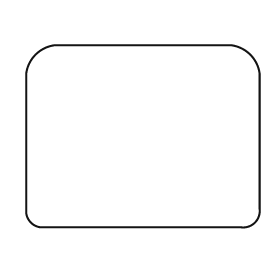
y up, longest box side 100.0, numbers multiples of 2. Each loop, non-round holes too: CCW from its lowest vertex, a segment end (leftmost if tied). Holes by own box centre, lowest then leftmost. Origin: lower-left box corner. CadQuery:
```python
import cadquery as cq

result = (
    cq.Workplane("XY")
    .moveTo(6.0, 0.0)
    .lineTo(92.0, 0.0)
    .threePointArc((98.0, 2.0), (100.0, 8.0))
    .lineTo(100.0, 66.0)
    .threePointArc((96.0, 74.0), (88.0, 78.0))
    .lineTo(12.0, 78.0)
    .threePointArc((4.0, 74.0), (0.0, 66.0))
    .lineTo(0.0, 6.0)
    .threePointArc((2.0, 2.0), (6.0, 0.0))
    .close()
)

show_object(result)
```